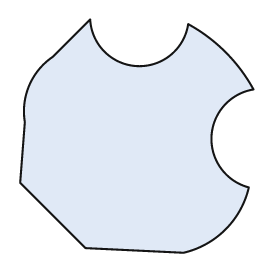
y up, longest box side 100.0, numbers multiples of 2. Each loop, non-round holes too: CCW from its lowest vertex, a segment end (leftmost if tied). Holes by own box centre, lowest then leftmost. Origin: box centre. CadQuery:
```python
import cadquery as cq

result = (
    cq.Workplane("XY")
    .moveTo(20.0, -50.0)
    .threePointArc((38.0, -40.0), (48.0, -22.0))
    .threePointArc((32.0, 0.0), (50.0, 20.0))
    .threePointArc((38.0, 36.0), (22.0, 48.0))
    .threePointArc((0.0, 30.0), (-20.0, 50.0))
    .lineTo(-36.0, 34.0)
    .threePointArc((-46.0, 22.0), (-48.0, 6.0))
    .lineTo(-50.0, -20.0)
    .lineTo(-22.0, -48.0)
    .close()
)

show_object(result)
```